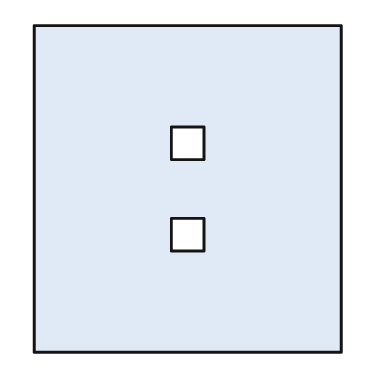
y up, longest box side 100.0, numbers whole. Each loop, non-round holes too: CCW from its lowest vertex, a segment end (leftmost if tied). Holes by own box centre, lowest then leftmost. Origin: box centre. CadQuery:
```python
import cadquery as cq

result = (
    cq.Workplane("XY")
    .moveTo(-47.0, -50.0)
    .lineTo(47.0, -50.0)
    .lineTo(47.0, 50.0)
    .lineTo(-47.0, 50.0)
    .close()
    .moveTo(-5.0, -19.0)
    .lineTo(5.0, -19.0)
    .lineTo(5.0, -9.0)
    .lineTo(-5.0, -9.0)
    .close()
    .moveTo(-5.0, 9.0)
    .lineTo(5.0, 9.0)
    .lineTo(5.0, 19.0)
    .lineTo(-5.0, 19.0)
    .close()
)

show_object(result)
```